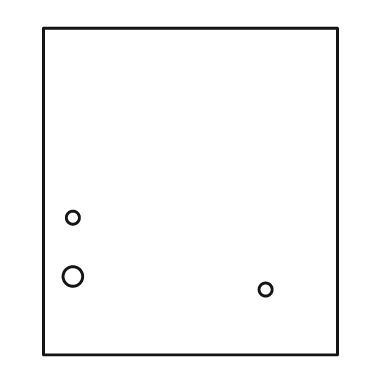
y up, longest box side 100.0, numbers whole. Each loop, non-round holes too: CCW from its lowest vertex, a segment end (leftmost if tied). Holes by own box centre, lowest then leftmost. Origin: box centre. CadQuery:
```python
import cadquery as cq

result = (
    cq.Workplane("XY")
    .moveTo(-45.0, -50.0)
    .lineTo(45.0, -50.0)
    .lineTo(45.0, 50.0)
    .lineTo(-45.0, 50.0)
    .close()
    .moveTo(23.0, -30.0)
    .circle(2.0)
    .moveTo(-36.0, -26.0)
    .circle(3.0)
    .moveTo(-36.0, -8.0)
    .circle(2.0)
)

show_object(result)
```